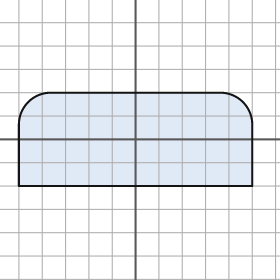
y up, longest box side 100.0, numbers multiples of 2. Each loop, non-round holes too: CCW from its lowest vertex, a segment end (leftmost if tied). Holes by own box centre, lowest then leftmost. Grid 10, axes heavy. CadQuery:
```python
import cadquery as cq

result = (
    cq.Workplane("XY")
    .moveTo(-50.0, -20.0)
    .lineTo(50.0, -20.0)
    .lineTo(50.0, 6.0)
    .threePointArc((46.0, 16.0), (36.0, 20.0))
    .lineTo(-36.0, 20.0)
    .threePointArc((-46.0, 16.0), (-50.0, 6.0))
    .close()
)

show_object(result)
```